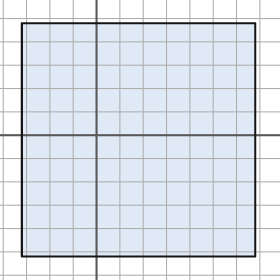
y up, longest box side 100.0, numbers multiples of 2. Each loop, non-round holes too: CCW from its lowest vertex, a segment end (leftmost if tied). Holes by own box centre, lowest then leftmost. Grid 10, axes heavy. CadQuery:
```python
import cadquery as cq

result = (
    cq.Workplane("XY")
    .moveTo(-32.0, -52.0)
    .lineTo(68.0, -52.0)
    .lineTo(68.0, 48.0)
    .lineTo(-32.0, 48.0)
    .close()
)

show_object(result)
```